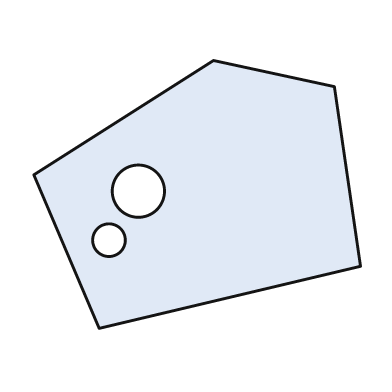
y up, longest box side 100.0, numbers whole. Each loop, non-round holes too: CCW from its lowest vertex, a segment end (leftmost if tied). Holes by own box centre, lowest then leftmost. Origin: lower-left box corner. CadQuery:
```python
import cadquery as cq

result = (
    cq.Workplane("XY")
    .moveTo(20.0, 0.0)
    .lineTo(100.0, 19.0)
    .lineTo(92.0, 74.0)
    .lineTo(55.0, 82.0)
    .lineTo(0.0, 47.0)
    .close()
    .moveTo(23.0, 27.0)
    .circle(5.0)
    .moveTo(32.0, 42.0)
    .circle(8.0)
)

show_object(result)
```